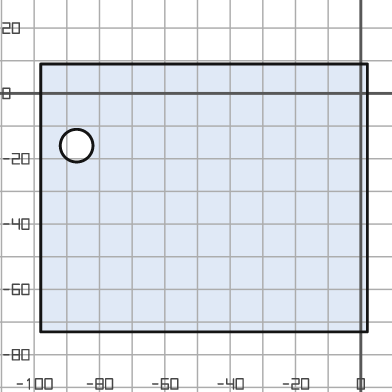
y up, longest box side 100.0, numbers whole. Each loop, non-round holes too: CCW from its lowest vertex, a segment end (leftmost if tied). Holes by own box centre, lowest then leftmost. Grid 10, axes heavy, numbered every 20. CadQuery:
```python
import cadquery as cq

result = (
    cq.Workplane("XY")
    .moveTo(-98.0, -73.0)
    .lineTo(2.0, -73.0)
    .lineTo(2.0, 9.0)
    .lineTo(-98.0, 9.0)
    .close()
    .moveTo(-87.0, -16.0)
    .circle(5.0)
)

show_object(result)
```